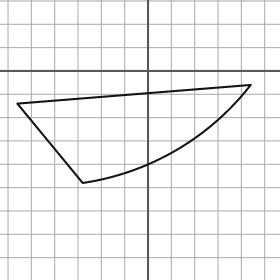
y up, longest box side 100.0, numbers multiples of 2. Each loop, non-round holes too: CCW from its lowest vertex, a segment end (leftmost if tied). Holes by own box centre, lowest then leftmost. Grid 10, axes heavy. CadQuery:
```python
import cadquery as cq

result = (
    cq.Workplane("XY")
    .moveTo(-28.0, -48.0)
    .threePointArc((12.0, -34.0), (44.0, -6.0))
    .lineTo(-56.0, -14.0)
    .close()
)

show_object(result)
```